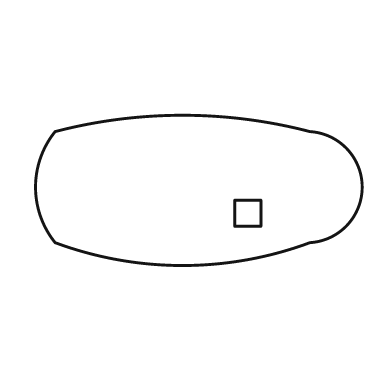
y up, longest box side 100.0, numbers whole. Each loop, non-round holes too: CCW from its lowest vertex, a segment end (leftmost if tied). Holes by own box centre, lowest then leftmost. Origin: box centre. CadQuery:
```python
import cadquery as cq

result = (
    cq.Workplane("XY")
    .moveTo(-44.0, -16.0)
    .threePointArc((-5.0, -23.0), (34.0, -16.0))
    .threePointArc((50.0, 1.0), (34.0, 18.0))
    .threePointArc((-5.0, 23.0), (-44.0, 18.0))
    .threePointArc((-50.0, 1.0), (-44.0, -16.0))
    .close()
    .moveTo(11.0, -11.0)
    .lineTo(19.0, -11.0)
    .lineTo(19.0, -3.0)
    .lineTo(11.0, -3.0)
    .close()
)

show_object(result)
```